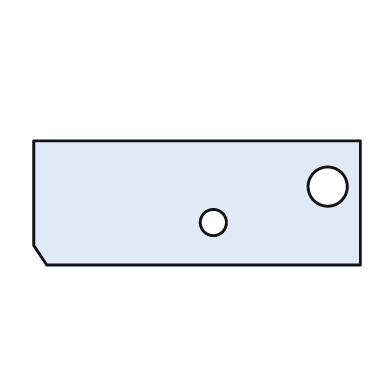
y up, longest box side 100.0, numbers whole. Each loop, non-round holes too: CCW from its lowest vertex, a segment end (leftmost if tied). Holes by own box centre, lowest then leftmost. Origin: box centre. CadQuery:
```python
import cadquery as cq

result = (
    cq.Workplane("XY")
    .moveTo(-46.0, -19.0)
    .lineTo(50.0, -19.0)
    .lineTo(50.0, 19.0)
    .lineTo(-50.0, 19.0)
    .lineTo(-50.0, -13.0)
    .close()
    .moveTo(5.0, -6.0)
    .circle(4.0)
    .moveTo(40.0, 5.0)
    .circle(6.0)
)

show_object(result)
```